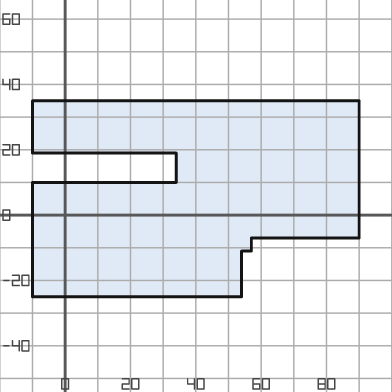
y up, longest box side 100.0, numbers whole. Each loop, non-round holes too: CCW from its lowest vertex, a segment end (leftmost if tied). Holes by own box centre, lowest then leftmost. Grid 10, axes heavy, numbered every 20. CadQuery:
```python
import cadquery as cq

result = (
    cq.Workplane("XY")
    .moveTo(-10.0, -25.0)
    .lineTo(54.0, -25.0)
    .lineTo(54.0, -11.0)
    .lineTo(57.0, -11.0)
    .lineTo(57.0, -7.0)
    .lineTo(90.0, -7.0)
    .lineTo(90.0, 35.0)
    .lineTo(-10.0, 35.0)
    .lineTo(-10.0, 19.0)
    .lineTo(34.0, 19.0)
    .lineTo(34.0, 10.0)
    .lineTo(-10.0, 10.0)
    .close()
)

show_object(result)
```